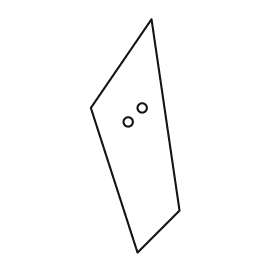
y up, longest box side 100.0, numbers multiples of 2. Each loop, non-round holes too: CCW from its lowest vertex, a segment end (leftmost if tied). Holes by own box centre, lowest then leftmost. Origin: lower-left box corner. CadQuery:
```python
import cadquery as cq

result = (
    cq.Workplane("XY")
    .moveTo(20.0, 0.0)
    .lineTo(38.0, 18.0)
    .lineTo(26.0, 100.0)
    .lineTo(0.0, 62.0)
    .close()
    .moveTo(16.0, 56.0)
    .circle(2.0)
    .moveTo(22.0, 62.0)
    .circle(2.0)
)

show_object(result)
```